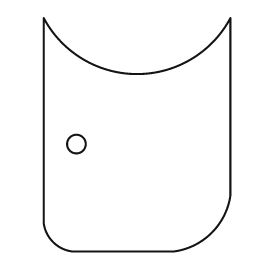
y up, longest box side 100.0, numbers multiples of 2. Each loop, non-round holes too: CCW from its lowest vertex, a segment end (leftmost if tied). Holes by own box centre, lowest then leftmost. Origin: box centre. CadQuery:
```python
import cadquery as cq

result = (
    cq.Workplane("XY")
    .moveTo(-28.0, -50.0)
    .lineTo(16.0, -50.0)
    .threePointArc((32.0, -42.0), (40.0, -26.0))
    .lineTo(40.0, 50.0)
    .threePointArc((0.0, 26.0), (-40.0, 50.0))
    .lineTo(-40.0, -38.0)
    .threePointArc((-36.0, -46.0), (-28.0, -50.0))
    .close()
    .moveTo(-26.0, -4.0)
    .circle(4.0)
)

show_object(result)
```